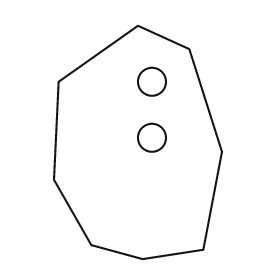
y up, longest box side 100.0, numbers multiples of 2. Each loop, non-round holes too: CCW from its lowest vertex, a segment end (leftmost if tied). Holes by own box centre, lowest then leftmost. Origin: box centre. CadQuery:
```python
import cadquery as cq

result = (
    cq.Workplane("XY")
    .moveTo(2.0, -50.0)
    .lineTo(28.0, -46.0)
    .lineTo(36.0, -4.0)
    .lineTo(22.0, 40.0)
    .lineTo(0.0, 50.0)
    .lineTo(-34.0, 26.0)
    .lineTo(-36.0, -16.0)
    .lineTo(-20.0, -44.0)
    .close()
    .moveTo(6.0, 2.0)
    .circle(6.0)
    .moveTo(6.0, 26.0)
    .circle(6.0)
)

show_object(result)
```